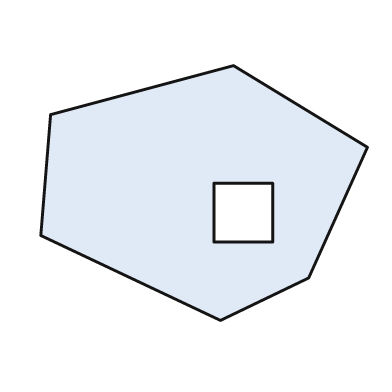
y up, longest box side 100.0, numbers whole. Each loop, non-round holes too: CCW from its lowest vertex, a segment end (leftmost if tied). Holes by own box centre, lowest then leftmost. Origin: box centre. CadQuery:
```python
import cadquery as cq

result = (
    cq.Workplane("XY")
    .moveTo(5.0, -39.0)
    .lineTo(32.0, -26.0)
    .lineTo(50.0, 14.0)
    .lineTo(9.0, 39.0)
    .lineTo(-47.0, 24.0)
    .lineTo(-50.0, -13.0)
    .close()
    .moveTo(3.0, -15.0)
    .lineTo(21.0, -15.0)
    .lineTo(21.0, 3.0)
    .lineTo(3.0, 3.0)
    .close()
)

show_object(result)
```